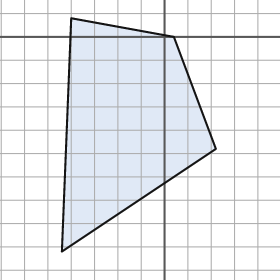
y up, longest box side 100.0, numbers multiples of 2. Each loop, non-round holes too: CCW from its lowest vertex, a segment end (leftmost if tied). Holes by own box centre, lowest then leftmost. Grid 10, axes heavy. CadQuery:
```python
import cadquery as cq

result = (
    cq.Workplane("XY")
    .moveTo(-44.0, -92.0)
    .lineTo(22.0, -48.0)
    .lineTo(4.0, 0.0)
    .lineTo(-40.0, 8.0)
    .close()
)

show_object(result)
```